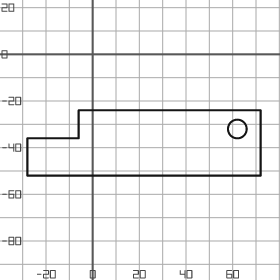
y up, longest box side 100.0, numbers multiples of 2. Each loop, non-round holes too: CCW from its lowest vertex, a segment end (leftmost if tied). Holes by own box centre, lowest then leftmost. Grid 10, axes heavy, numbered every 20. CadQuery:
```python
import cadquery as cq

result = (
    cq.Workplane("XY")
    .moveTo(-28.0, -52.0)
    .lineTo(72.0, -52.0)
    .lineTo(72.0, -24.0)
    .lineTo(-6.0, -24.0)
    .lineTo(-6.0, -36.0)
    .lineTo(-28.0, -36.0)
    .close()
    .moveTo(62.0, -32.0)
    .circle(4.0)
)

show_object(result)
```